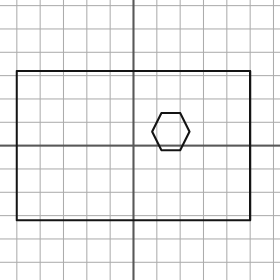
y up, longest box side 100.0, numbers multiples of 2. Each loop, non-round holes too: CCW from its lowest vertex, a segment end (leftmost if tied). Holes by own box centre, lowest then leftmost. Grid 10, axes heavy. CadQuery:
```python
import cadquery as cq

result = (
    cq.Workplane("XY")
    .moveTo(-50.0, -32.0)
    .lineTo(50.0, -32.0)
    .lineTo(50.0, 32.0)
    .lineTo(-50.0, 32.0)
    .close()
    .moveTo(12.0, -2.0)
    .lineTo(20.0, -2.0)
    .lineTo(24.0, 6.0)
    .lineTo(20.0, 14.0)
    .lineTo(12.0, 14.0)
    .lineTo(8.0, 6.0)
    .close()
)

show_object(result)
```